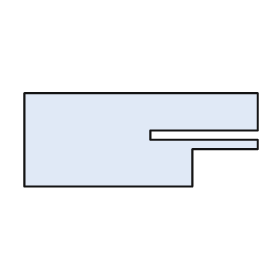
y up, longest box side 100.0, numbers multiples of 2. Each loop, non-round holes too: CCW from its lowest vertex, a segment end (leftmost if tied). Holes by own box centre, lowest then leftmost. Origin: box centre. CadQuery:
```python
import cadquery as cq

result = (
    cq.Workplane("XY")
    .moveTo(-50.0, -20.0)
    .lineTo(22.0, -20.0)
    .lineTo(22.0, -4.0)
    .lineTo(50.0, -4.0)
    .lineTo(50.0, 0.0)
    .lineTo(4.0, 0.0)
    .lineTo(4.0, 4.0)
    .lineTo(50.0, 4.0)
    .lineTo(50.0, 20.0)
    .lineTo(-50.0, 20.0)
    .close()
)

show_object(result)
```